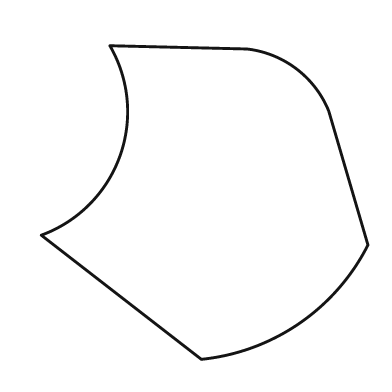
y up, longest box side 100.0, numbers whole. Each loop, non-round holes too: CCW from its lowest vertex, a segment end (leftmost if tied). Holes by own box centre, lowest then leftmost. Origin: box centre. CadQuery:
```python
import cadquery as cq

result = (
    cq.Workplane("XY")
    .moveTo(-1.0, -48.0)
    .threePointArc((29.0, -37.0), (50.0, -13.0))
    .lineTo(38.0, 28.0)
    .threePointArc((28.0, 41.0), (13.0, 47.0))
    .lineTo(-29.0, 48.0)
    .threePointArc((-26.0, 14.0), (-50.0, -10.0))
    .close()
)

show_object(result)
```